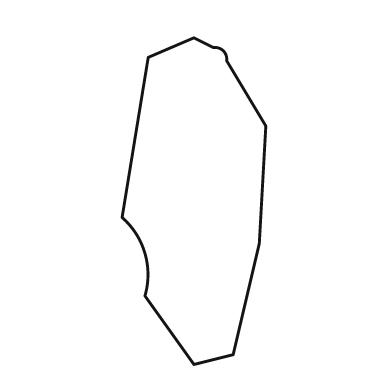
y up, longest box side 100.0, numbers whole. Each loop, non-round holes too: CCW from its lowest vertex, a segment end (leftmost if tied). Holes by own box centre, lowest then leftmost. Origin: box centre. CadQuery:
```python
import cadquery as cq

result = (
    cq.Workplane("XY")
    .moveTo(0.0, -50.0)
    .lineTo(12.0, -47.0)
    .lineTo(20.0, -13.0)
    .lineTo(22.0, 23.0)
    .lineTo(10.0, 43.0)
    .threePointArc((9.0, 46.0), (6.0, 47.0))
    .lineTo(0.0, 50.0)
    .lineTo(-14.0, 44.0)
    .lineTo(-22.0, -5.0)
    .threePointArc((-15.0, -16.0), (-15.0, -29.0))
    .close()
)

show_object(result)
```